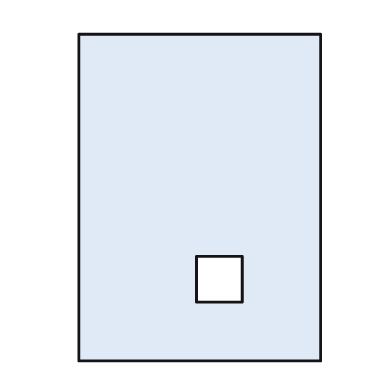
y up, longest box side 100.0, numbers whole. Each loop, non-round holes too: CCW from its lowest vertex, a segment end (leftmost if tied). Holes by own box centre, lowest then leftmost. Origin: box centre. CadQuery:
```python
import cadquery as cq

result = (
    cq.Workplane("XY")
    .moveTo(-37.0, -50.0)
    .lineTo(37.0, -50.0)
    .lineTo(37.0, 50.0)
    .lineTo(-37.0, 50.0)
    .close()
    .moveTo(-1.0, -32.0)
    .lineTo(13.0, -32.0)
    .lineTo(13.0, -18.0)
    .lineTo(-1.0, -18.0)
    .close()
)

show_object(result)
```